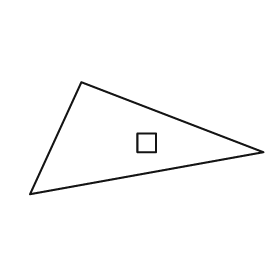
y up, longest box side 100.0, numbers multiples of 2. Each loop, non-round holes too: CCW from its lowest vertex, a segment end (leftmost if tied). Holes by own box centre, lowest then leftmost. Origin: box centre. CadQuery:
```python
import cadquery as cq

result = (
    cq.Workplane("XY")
    .moveTo(-50.0, -24.0)
    .lineTo(50.0, -6.0)
    .lineTo(-28.0, 24.0)
    .close()
    .moveTo(-4.0, -6.0)
    .lineTo(4.0, -6.0)
    .lineTo(4.0, 2.0)
    .lineTo(-4.0, 2.0)
    .close()
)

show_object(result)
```